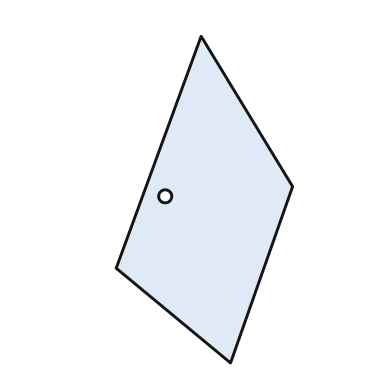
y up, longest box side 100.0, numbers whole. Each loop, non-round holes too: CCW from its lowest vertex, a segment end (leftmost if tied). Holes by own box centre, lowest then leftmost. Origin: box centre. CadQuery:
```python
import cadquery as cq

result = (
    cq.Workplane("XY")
    .moveTo(8.0, -50.0)
    .lineTo(27.0, 4.0)
    .lineTo(-1.0, 50.0)
    .lineTo(-27.0, -21.0)
    .close()
    .moveTo(-12.0, 1.0)
    .circle(2.0)
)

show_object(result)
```